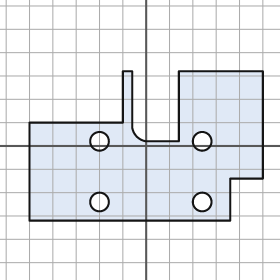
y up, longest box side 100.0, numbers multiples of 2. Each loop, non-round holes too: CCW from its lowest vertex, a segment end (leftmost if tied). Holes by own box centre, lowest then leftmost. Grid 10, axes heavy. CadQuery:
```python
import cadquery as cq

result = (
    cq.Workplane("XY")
    .moveTo(-50.0, -32.0)
    .lineTo(36.0, -32.0)
    .lineTo(36.0, -14.0)
    .lineTo(50.0, -14.0)
    .lineTo(50.0, 32.0)
    .lineTo(14.0, 32.0)
    .lineTo(14.0, 2.0)
    .lineTo(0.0, 2.0)
    .threePointArc((-4.0, 4.0), (-6.0, 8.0))
    .lineTo(-6.0, 32.0)
    .lineTo(-10.0, 32.0)
    .lineTo(-10.0, 10.0)
    .lineTo(-50.0, 10.0)
    .close()
    .moveTo(-20.0, -24.0)
    .circle(4.0)
    .moveTo(24.0, -24.0)
    .circle(4.0)
    .moveTo(-20.0, 2.0)
    .circle(4.0)
    .moveTo(24.0, 2.0)
    .circle(4.0)
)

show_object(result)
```